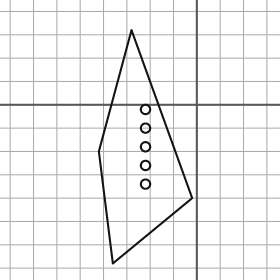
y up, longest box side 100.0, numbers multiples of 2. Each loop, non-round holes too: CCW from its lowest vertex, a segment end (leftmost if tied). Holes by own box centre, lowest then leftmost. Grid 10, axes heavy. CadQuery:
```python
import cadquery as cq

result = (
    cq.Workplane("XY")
    .moveTo(-36.0, -68.0)
    .lineTo(-2.0, -40.0)
    .lineTo(-28.0, 32.0)
    .lineTo(-42.0, -20.0)
    .close()
    .moveTo(-22.0, -34.0)
    .circle(2.0)
    .moveTo(-22.0, -26.0)
    .circle(2.0)
    .moveTo(-22.0, -18.0)
    .circle(2.0)
    .moveTo(-22.0, -10.0)
    .circle(2.0)
    .moveTo(-22.0, -2.0)
    .circle(2.0)
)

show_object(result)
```